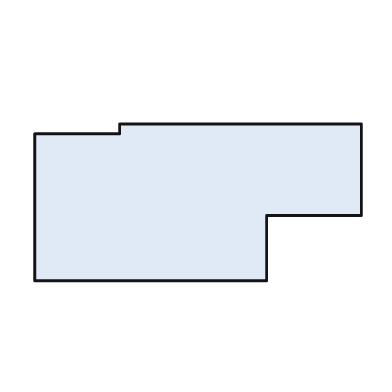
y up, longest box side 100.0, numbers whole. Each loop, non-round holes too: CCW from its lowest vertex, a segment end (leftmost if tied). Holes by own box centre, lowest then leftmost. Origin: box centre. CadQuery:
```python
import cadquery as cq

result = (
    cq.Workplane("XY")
    .moveTo(-50.0, -24.0)
    .lineTo(21.0, -24.0)
    .lineTo(21.0, -4.0)
    .lineTo(50.0, -4.0)
    .lineTo(50.0, 24.0)
    .lineTo(-24.0, 24.0)
    .lineTo(-24.0, 21.0)
    .lineTo(-50.0, 21.0)
    .close()
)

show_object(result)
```